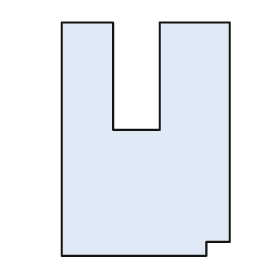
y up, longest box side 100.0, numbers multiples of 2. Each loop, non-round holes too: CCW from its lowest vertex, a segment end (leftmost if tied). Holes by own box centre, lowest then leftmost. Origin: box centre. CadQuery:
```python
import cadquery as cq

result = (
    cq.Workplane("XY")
    .moveTo(-36.0, -50.0)
    .lineTo(26.0, -50.0)
    .lineTo(26.0, -44.0)
    .lineTo(36.0, -44.0)
    .lineTo(36.0, 50.0)
    .lineTo(6.0, 50.0)
    .lineTo(6.0, 4.0)
    .lineTo(-14.0, 4.0)
    .lineTo(-14.0, 50.0)
    .lineTo(-36.0, 50.0)
    .close()
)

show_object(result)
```